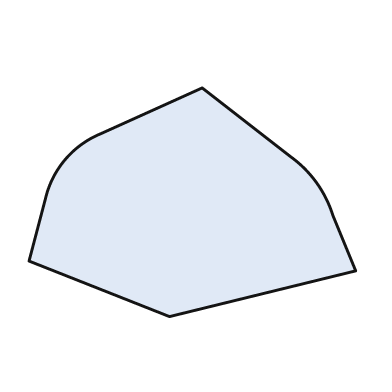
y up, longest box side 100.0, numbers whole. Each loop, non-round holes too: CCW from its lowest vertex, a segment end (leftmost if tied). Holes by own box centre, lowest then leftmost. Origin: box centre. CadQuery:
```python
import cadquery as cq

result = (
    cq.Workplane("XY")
    .moveTo(-7.0, -35.0)
    .lineTo(50.0, -21.0)
    .lineTo(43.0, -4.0)
    .threePointArc((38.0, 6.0), (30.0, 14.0))
    .lineTo(3.0, 35.0)
    .lineTo(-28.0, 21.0)
    .threePointArc((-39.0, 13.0), (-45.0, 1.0))
    .lineTo(-50.0, -18.0)
    .close()
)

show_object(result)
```